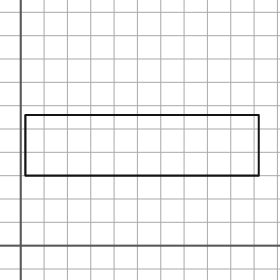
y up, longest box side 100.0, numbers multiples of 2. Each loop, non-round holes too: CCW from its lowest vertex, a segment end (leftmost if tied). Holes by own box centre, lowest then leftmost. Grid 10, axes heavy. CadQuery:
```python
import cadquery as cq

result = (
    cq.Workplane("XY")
    .moveTo(2.0, 30.0)
    .lineTo(102.0, 30.0)
    .lineTo(102.0, 56.0)
    .lineTo(2.0, 56.0)
    .close()
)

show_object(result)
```